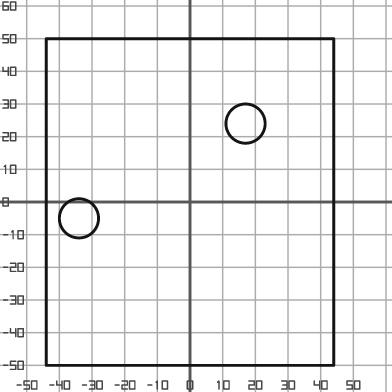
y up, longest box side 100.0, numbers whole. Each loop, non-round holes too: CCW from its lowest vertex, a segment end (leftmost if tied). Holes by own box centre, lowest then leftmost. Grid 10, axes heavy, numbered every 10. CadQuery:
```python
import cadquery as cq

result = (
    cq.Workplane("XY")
    .moveTo(-44.0, -50.0)
    .lineTo(44.0, -50.0)
    .lineTo(44.0, 50.0)
    .lineTo(-44.0, 50.0)
    .close()
    .moveTo(-34.0, -5.0)
    .circle(6.0)
    .moveTo(17.0, 24.0)
    .circle(6.0)
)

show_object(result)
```